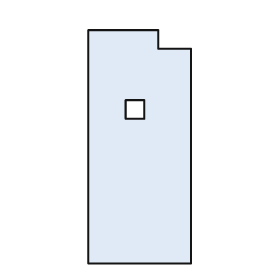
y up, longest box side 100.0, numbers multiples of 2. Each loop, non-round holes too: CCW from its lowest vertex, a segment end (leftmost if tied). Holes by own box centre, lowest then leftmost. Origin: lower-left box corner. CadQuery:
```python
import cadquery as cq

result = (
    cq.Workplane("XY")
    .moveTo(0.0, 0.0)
    .lineTo(44.0, 0.0)
    .lineTo(44.0, 92.0)
    .lineTo(30.0, 92.0)
    .lineTo(30.0, 100.0)
    .lineTo(0.0, 100.0)
    .close()
    .moveTo(16.0, 62.0)
    .lineTo(24.0, 62.0)
    .lineTo(24.0, 70.0)
    .lineTo(16.0, 70.0)
    .close()
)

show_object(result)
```